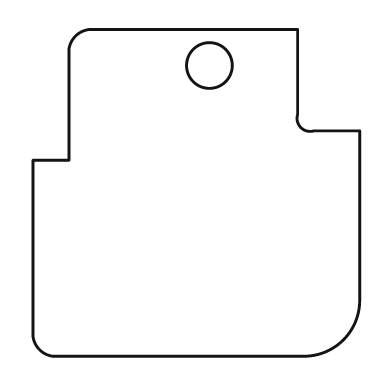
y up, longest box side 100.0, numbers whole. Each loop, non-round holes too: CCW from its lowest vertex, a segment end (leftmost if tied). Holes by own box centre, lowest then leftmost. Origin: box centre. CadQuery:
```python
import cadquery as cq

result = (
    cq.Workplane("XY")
    .moveTo(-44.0, -50.0)
    .lineTo(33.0, -50.0)
    .threePointArc((45.0, -45.0), (50.0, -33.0))
    .lineTo(50.0, 19.0)
    .lineTo(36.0, 19.0)
    .threePointArc((32.0, 20.0), (31.0, 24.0))
    .lineTo(31.0, 50.0)
    .lineTo(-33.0, 50.0)
    .threePointArc((-37.0, 48.0), (-39.0, 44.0))
    .lineTo(-39.0, 10.0)
    .lineTo(-50.0, 10.0)
    .lineTo(-50.0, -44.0)
    .threePointArc((-48.0, -48.0), (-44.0, -50.0))
    .close()
    .moveTo(4.0, 39.0)
    .circle(7.0)
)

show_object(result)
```